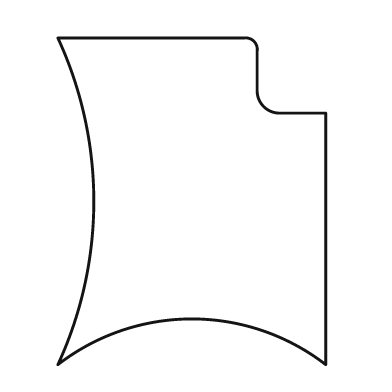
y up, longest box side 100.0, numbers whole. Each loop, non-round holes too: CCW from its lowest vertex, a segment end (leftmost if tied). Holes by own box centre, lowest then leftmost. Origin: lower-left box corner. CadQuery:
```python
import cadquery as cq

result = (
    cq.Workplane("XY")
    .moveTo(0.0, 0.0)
    .threePointArc((41.0, 14.0), (82.0, 0.0))
    .lineTo(82.0, 77.0)
    .lineTo(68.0, 77.0)
    .threePointArc((63.0, 79.0), (61.0, 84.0))
    .lineTo(61.0, 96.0)
    .threePointArc((60.0, 99.0), (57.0, 100.0))
    .lineTo(0.0, 100.0)
    .threePointArc((11.0, 50.0), (0.0, 0.0))
    .close()
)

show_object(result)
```